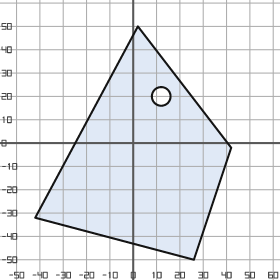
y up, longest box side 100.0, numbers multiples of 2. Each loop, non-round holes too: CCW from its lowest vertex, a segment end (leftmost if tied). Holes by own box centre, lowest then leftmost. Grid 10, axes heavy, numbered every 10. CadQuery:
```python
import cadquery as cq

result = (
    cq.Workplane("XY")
    .moveTo(26.0, -50.0)
    .lineTo(42.0, -2.0)
    .lineTo(2.0, 50.0)
    .lineTo(-42.0, -32.0)
    .close()
    .moveTo(12.0, 20.0)
    .circle(4.0)
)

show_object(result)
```